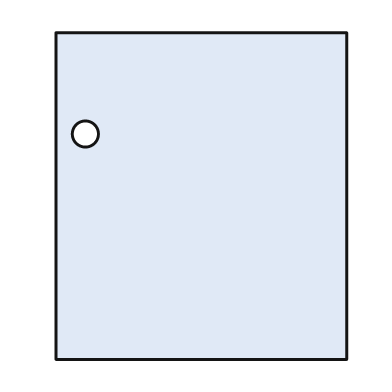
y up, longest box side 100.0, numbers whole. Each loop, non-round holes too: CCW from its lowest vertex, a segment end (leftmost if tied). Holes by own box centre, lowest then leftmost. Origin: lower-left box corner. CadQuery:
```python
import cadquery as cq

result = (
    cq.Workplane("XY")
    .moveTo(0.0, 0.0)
    .lineTo(89.0, 0.0)
    .lineTo(89.0, 100.0)
    .lineTo(0.0, 100.0)
    .close()
    .moveTo(9.0, 69.0)
    .circle(4.0)
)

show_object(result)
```